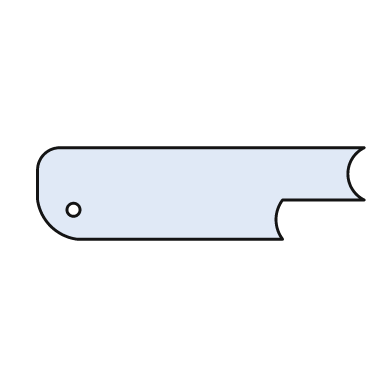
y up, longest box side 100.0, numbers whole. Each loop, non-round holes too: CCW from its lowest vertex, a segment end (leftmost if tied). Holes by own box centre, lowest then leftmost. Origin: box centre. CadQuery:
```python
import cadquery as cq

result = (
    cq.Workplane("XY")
    .moveTo(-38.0, -14.0)
    .lineTo(25.0, -14.0)
    .threePointArc((23.0, -8.0), (25.0, -2.0))
    .lineTo(50.0, -2.0)
    .threePointArc((45.0, 6.0), (50.0, 14.0))
    .lineTo(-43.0, 14.0)
    .threePointArc((-48.0, 12.0), (-50.0, 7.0))
    .lineTo(-50.0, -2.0)
    .threePointArc((-46.0, -10.0), (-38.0, -14.0))
    .close()
    .moveTo(-39.0, -5.0)
    .circle(2.0)
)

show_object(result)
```